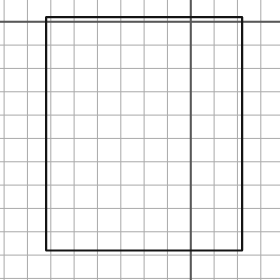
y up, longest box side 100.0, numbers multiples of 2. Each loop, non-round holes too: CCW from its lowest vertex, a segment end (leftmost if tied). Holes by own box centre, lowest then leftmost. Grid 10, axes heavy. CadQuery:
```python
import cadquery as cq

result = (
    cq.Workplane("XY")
    .moveTo(-62.0, -98.0)
    .lineTo(22.0, -98.0)
    .lineTo(22.0, 2.0)
    .lineTo(-62.0, 2.0)
    .close()
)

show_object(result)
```